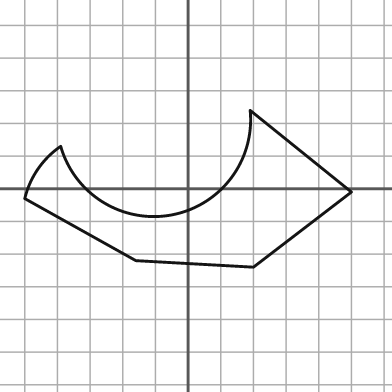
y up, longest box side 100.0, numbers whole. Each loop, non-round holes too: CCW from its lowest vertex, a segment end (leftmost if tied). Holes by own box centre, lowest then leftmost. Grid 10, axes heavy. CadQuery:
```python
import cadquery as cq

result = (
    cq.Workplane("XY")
    .moveTo(20.0, -24.0)
    .lineTo(50.0, -1.0)
    .lineTo(19.0, 24.0)
    .threePointArc((-5.0, -8.0), (-39.0, 13.0))
    .threePointArc((-46.0, 6.0), (-50.0, -3.0))
    .lineTo(-16.0, -22.0)
    .close()
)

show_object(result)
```